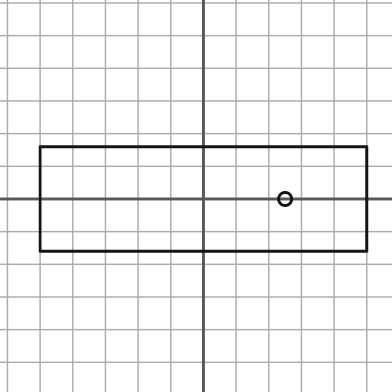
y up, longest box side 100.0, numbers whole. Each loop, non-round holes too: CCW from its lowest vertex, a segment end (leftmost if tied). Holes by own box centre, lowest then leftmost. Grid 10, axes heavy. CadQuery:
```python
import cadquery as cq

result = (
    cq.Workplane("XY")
    .moveTo(-50.0, -16.0)
    .lineTo(50.0, -16.0)
    .lineTo(50.0, 16.0)
    .lineTo(-50.0, 16.0)
    .close()
    .moveTo(25.0, 0.0)
    .circle(2.0)
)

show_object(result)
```